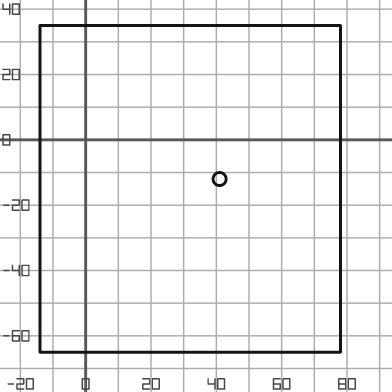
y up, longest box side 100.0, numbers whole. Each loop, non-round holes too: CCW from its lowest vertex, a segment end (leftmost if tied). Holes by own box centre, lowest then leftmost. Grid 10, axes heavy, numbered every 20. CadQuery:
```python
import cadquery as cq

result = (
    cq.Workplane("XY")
    .moveTo(-14.0, -65.0)
    .lineTo(78.0, -65.0)
    .lineTo(78.0, 35.0)
    .lineTo(-14.0, 35.0)
    .close()
    .moveTo(41.0, -12.0)
    .circle(2.0)
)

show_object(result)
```